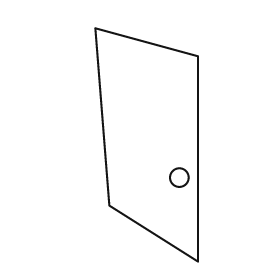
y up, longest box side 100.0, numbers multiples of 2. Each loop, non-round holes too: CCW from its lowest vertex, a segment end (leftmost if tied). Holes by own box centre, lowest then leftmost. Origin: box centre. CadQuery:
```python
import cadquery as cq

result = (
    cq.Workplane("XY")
    .moveTo(22.0, -50.0)
    .lineTo(22.0, 38.0)
    .lineTo(-22.0, 50.0)
    .lineTo(-16.0, -26.0)
    .close()
    .moveTo(14.0, -14.0)
    .circle(4.0)
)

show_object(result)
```